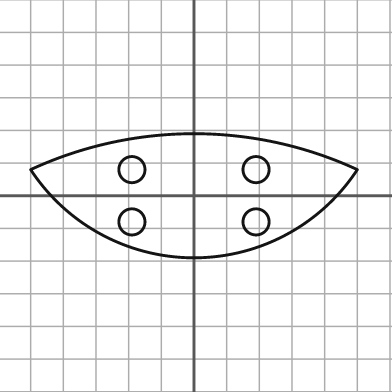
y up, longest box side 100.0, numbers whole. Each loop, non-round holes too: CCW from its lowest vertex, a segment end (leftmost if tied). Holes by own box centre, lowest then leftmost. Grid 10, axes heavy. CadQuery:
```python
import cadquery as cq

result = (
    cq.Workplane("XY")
    .moveTo(-50.0, 8.0)
    .threePointArc((0.0, -19.0), (50.0, 8.0))
    .threePointArc((0.0, 19.0), (-50.0, 8.0))
    .close()
    .moveTo(-19.0, -8.0)
    .circle(4.0)
    .moveTo(19.0, -8.0)
    .circle(4.0)
    .moveTo(-19.0, 8.0)
    .circle(4.0)
    .moveTo(19.0, 8.0)
    .circle(4.0)
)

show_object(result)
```